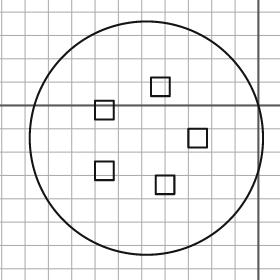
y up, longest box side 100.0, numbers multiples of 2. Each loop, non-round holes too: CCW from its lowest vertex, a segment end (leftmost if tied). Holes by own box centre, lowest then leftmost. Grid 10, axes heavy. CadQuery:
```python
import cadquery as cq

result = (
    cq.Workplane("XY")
    .moveTo(-48.0, -14.0)
    .circle(50.0)
    .moveTo(-44.0, -38.0)
    .lineTo(-36.0, -38.0)
    .lineTo(-36.0, -30.0)
    .lineTo(-44.0, -30.0)
    .close()
    .moveTo(-70.0, -32.0)
    .lineTo(-62.0, -32.0)
    .lineTo(-62.0, -24.0)
    .lineTo(-70.0, -24.0)
    .close()
    .moveTo(-30.0, -18.0)
    .lineTo(-22.0, -18.0)
    .lineTo(-22.0, -10.0)
    .lineTo(-30.0, -10.0)
    .close()
    .moveTo(-70.0, -6.0)
    .lineTo(-62.0, -6.0)
    .lineTo(-62.0, 2.0)
    .lineTo(-70.0, 2.0)
    .close()
    .moveTo(-46.0, 4.0)
    .lineTo(-38.0, 4.0)
    .lineTo(-38.0, 12.0)
    .lineTo(-46.0, 12.0)
    .close()
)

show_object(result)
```